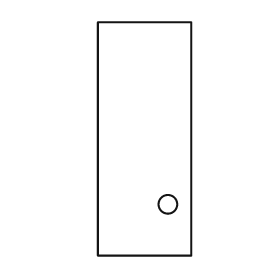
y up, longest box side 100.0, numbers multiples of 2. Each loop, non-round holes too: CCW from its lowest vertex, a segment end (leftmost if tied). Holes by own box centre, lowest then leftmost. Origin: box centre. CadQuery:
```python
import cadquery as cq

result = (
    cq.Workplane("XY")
    .moveTo(-20.0, -50.0)
    .lineTo(20.0, -50.0)
    .lineTo(20.0, 50.0)
    .lineTo(-20.0, 50.0)
    .close()
    .moveTo(10.0, -28.0)
    .circle(4.0)
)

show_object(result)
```